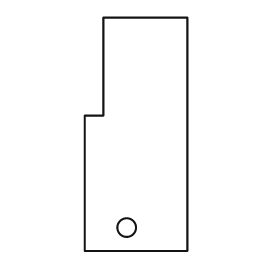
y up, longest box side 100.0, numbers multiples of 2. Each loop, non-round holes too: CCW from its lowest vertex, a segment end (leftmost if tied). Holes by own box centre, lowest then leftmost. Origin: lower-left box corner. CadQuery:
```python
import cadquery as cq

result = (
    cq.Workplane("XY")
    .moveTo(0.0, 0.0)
    .lineTo(44.0, 0.0)
    .lineTo(44.0, 100.0)
    .lineTo(8.0, 100.0)
    .lineTo(8.0, 58.0)
    .lineTo(0.0, 58.0)
    .close()
    .moveTo(18.0, 10.0)
    .circle(4.0)
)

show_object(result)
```